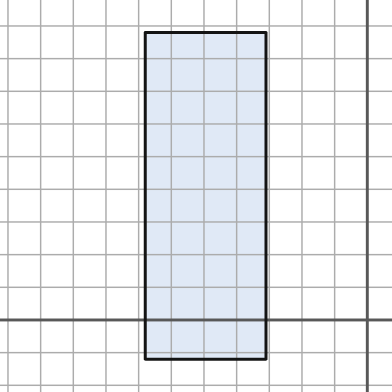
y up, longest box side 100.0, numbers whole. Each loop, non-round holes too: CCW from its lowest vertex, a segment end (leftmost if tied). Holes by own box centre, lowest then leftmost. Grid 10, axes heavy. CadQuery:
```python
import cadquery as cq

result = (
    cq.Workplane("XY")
    .moveTo(-68.0, -12.0)
    .lineTo(-31.0, -12.0)
    .lineTo(-31.0, 88.0)
    .lineTo(-68.0, 88.0)
    .close()
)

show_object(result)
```